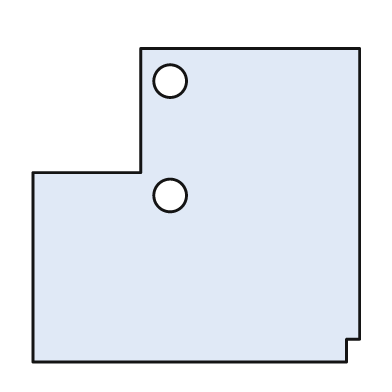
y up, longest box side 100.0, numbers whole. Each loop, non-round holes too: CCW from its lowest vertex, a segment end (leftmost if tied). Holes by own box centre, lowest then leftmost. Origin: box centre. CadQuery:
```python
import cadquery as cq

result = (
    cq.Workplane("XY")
    .moveTo(-50.0, -48.0)
    .lineTo(46.0, -48.0)
    .lineTo(46.0, -41.0)
    .lineTo(50.0, -41.0)
    .lineTo(50.0, 48.0)
    .lineTo(-17.0, 48.0)
    .lineTo(-17.0, 10.0)
    .lineTo(-50.0, 10.0)
    .close()
    .moveTo(-8.0, 3.0)
    .circle(5.0)
    .moveTo(-8.0, 38.0)
    .circle(5.0)
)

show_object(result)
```